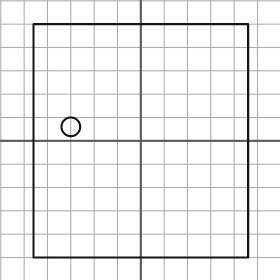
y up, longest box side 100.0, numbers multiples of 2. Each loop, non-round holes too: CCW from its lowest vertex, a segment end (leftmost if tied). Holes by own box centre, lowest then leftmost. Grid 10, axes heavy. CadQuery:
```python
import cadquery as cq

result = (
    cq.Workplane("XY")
    .moveTo(-46.0, -50.0)
    .lineTo(46.0, -50.0)
    .lineTo(46.0, 50.0)
    .lineTo(-46.0, 50.0)
    .close()
    .moveTo(-30.0, 6.0)
    .circle(4.0)
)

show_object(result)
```